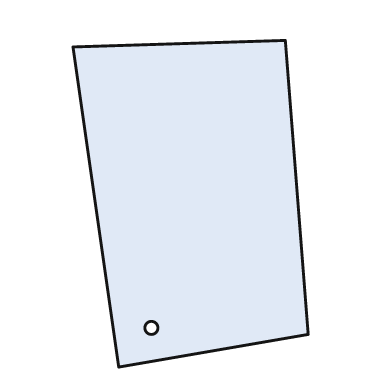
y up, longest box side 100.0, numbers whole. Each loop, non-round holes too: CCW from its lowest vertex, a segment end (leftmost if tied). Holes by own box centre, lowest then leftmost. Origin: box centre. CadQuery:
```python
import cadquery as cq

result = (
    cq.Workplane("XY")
    .moveTo(-22.0, -50.0)
    .lineTo(36.0, -40.0)
    .lineTo(29.0, 50.0)
    .lineTo(-36.0, 48.0)
    .close()
    .moveTo(-12.0, -38.0)
    .circle(2.0)
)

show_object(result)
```